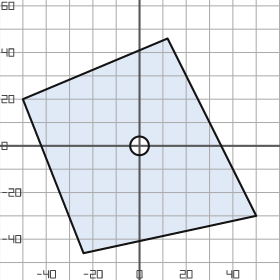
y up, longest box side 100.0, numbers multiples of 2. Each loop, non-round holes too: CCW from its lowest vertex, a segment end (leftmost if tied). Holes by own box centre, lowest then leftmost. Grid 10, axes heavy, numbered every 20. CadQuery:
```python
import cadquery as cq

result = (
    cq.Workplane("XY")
    .moveTo(-24.0, -46.0)
    .lineTo(50.0, -30.0)
    .lineTo(12.0, 46.0)
    .lineTo(-50.0, 20.0)
    .close()
    .moveTo(0.0, 0.0)
    .circle(4.0)
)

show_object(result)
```